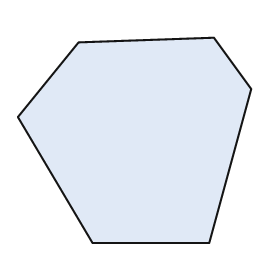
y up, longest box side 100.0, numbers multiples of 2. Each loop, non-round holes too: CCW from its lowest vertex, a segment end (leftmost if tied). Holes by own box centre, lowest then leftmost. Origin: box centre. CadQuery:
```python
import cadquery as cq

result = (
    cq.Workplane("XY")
    .moveTo(-18.0, -44.0)
    .lineTo(32.0, -44.0)
    .lineTo(50.0, 22.0)
    .lineTo(34.0, 44.0)
    .lineTo(-24.0, 42.0)
    .lineTo(-50.0, 10.0)
    .close()
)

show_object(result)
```